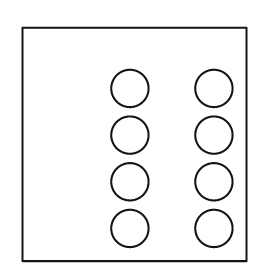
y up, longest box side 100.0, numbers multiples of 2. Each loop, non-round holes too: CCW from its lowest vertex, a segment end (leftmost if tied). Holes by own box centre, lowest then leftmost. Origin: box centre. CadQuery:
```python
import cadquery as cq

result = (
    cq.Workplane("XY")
    .moveTo(-48.0, -50.0)
    .lineTo(48.0, -50.0)
    .lineTo(48.0, 50.0)
    .lineTo(-48.0, 50.0)
    .close()
    .moveTo(-2.0, -36.0)
    .circle(8.0)
    .moveTo(34.0, -36.0)
    .circle(8.0)
    .moveTo(-2.0, -16.0)
    .circle(8.0)
    .moveTo(34.0, -16.0)
    .circle(8.0)
    .moveTo(-2.0, 4.0)
    .circle(8.0)
    .moveTo(34.0, 4.0)
    .circle(8.0)
    .moveTo(-2.0, 24.0)
    .circle(8.0)
    .moveTo(34.0, 24.0)
    .circle(8.0)
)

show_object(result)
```